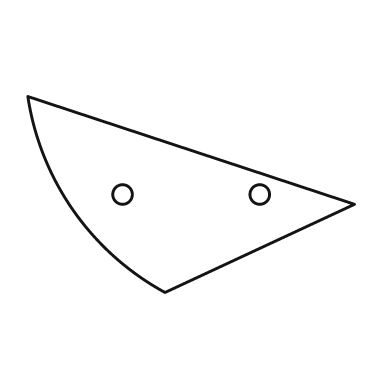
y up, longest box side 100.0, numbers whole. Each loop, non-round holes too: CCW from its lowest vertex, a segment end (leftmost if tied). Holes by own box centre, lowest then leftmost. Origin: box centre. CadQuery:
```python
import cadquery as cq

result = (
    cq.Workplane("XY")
    .moveTo(-8.0, -30.0)
    .lineTo(50.0, -3.0)
    .lineTo(-50.0, 30.0)
    .threePointArc((-36.0, -5.0), (-8.0, -30.0))
    .close()
    .moveTo(-21.0, 0.0)
    .circle(3.0)
    .moveTo(21.0, 0.0)
    .circle(3.0)
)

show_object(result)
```